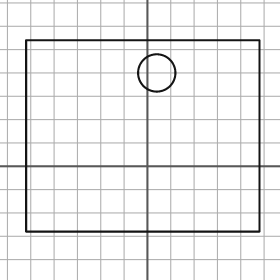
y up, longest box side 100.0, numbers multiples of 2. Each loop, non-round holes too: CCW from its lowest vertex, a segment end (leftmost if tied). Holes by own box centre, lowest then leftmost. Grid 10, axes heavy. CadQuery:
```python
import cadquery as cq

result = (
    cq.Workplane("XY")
    .moveTo(-52.0, -28.0)
    .lineTo(48.0, -28.0)
    .lineTo(48.0, 54.0)
    .lineTo(-52.0, 54.0)
    .close()
    .moveTo(4.0, 40.0)
    .circle(8.0)
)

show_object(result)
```